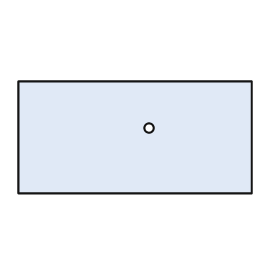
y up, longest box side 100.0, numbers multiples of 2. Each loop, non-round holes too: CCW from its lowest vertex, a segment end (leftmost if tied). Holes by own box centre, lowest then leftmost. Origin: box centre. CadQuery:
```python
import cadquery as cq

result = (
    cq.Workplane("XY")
    .moveTo(-50.0, -24.0)
    .lineTo(50.0, -24.0)
    .lineTo(50.0, 24.0)
    .lineTo(-50.0, 24.0)
    .close()
    .moveTo(6.0, 4.0)
    .circle(2.0)
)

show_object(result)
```